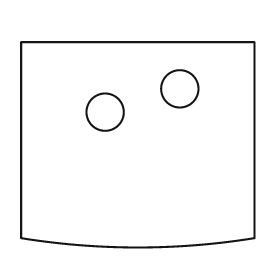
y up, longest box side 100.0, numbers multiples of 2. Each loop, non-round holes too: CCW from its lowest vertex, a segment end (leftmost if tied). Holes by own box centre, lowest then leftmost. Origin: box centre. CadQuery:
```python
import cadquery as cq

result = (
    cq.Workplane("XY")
    .moveTo(-50.0, -40.0)
    .threePointArc((0.0, -44.0), (50.0, -40.0))
    .lineTo(50.0, 44.0)
    .lineTo(-50.0, 44.0)
    .close()
    .moveTo(-14.0, 14.0)
    .circle(8.0)
    .moveTo(18.0, 24.0)
    .circle(8.0)
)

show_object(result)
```